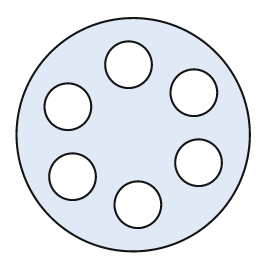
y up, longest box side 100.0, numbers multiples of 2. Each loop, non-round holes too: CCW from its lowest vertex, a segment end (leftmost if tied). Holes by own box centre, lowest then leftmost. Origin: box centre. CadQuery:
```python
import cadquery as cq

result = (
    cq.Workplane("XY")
    .moveTo(0.0, 0.0)
    .circle(50.0)
    .moveTo(2.0, -30.0)
    .circle(10.0)
    .moveTo(-26.0, -18.0)
    .circle(10.0)
    .moveTo(28.0, -12.0)
    .circle(10.0)
    .moveTo(-28.0, 12.0)
    .circle(10.0)
    .moveTo(26.0, 18.0)
    .circle(10.0)
    .moveTo(-2.0, 30.0)
    .circle(10.0)
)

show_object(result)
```